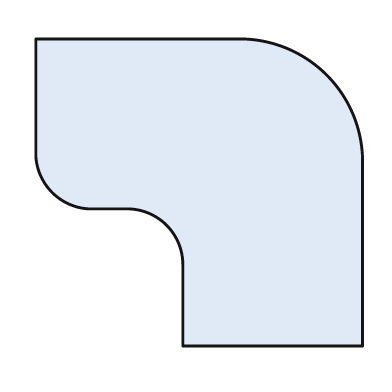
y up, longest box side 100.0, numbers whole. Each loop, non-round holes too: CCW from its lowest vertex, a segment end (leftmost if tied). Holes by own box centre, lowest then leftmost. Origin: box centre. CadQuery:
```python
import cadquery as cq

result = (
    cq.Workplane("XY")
    .moveTo(-5.0, -47.0)
    .lineTo(50.0, -47.0)
    .lineTo(50.0, 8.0)
    .threePointArc((39.0, 36.0), (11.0, 47.0))
    .lineTo(-50.0, 47.0)
    .lineTo(-50.0, 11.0)
    .threePointArc((-45.0, 0.0), (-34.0, -5.0))
    .lineTo(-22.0, -5.0)
    .threePointArc((-10.0, -10.0), (-5.0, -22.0))
    .close()
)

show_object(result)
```